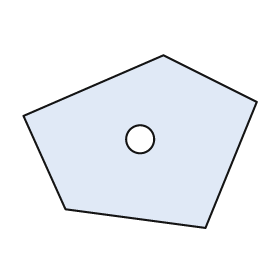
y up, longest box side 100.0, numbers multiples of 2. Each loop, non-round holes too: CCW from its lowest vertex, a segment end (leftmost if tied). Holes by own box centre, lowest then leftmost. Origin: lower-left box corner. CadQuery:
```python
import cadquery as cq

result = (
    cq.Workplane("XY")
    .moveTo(78.0, 0.0)
    .lineTo(100.0, 54.0)
    .lineTo(60.0, 74.0)
    .lineTo(0.0, 48.0)
    .lineTo(18.0, 8.0)
    .close()
    .moveTo(50.0, 38.0)
    .circle(6.0)
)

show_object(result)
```